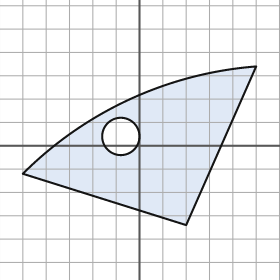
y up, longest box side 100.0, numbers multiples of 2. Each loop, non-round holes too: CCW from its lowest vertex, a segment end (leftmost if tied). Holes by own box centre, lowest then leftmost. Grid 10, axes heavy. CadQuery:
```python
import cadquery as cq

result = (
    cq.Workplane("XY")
    .moveTo(20.0, -34.0)
    .lineTo(50.0, 34.0)
    .threePointArc((-4.0, 20.0), (-50.0, -12.0))
    .close()
    .moveTo(-8.0, 4.0)
    .circle(8.0)
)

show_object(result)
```